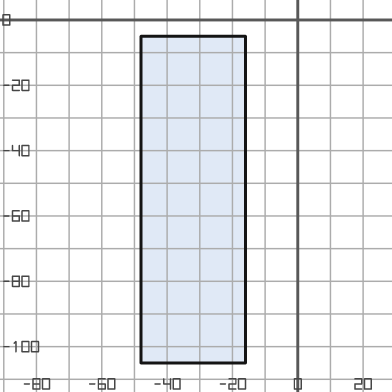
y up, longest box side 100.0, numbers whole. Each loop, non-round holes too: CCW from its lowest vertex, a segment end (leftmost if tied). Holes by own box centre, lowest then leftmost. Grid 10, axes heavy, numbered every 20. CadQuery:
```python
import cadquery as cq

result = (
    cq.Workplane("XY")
    .moveTo(-48.0, -105.0)
    .lineTo(-16.0, -105.0)
    .lineTo(-16.0, -5.0)
    .lineTo(-48.0, -5.0)
    .close()
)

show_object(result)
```